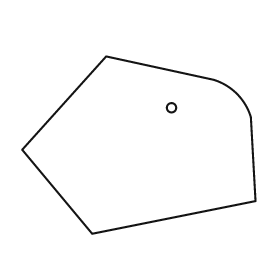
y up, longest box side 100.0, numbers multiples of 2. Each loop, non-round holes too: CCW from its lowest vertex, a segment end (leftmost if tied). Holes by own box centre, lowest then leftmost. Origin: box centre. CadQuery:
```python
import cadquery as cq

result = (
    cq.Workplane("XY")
    .moveTo(-20.0, -38.0)
    .lineTo(50.0, -24.0)
    .lineTo(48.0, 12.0)
    .threePointArc((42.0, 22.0), (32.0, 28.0))
    .lineTo(-14.0, 38.0)
    .lineTo(-50.0, -2.0)
    .close()
    .moveTo(14.0, 16.0)
    .circle(2.0)
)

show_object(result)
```